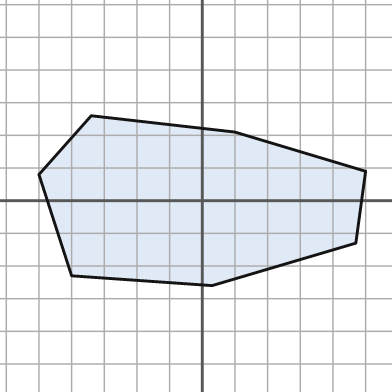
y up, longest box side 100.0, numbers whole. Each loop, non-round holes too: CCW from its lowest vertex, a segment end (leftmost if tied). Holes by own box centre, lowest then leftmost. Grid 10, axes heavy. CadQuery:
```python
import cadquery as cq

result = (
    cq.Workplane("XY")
    .moveTo(3.0, -26.0)
    .lineTo(47.0, -13.0)
    .lineTo(50.0, 9.0)
    .lineTo(10.0, 21.0)
    .lineTo(-34.0, 26.0)
    .lineTo(-50.0, 8.0)
    .lineTo(-40.0, -23.0)
    .close()
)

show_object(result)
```